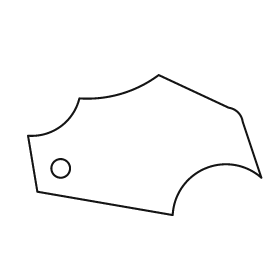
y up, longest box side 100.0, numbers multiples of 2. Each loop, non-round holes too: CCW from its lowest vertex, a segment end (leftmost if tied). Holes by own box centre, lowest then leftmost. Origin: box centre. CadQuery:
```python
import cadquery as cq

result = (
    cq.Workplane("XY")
    .moveTo(12.0, -30.0)
    .threePointArc((26.0, -10.0), (50.0, -14.0))
    .lineTo(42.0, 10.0)
    .threePointArc((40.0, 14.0), (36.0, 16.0))
    .lineTo(6.0, 30.0)
    .threePointArc((-10.0, 22.0), (-28.0, 20.0))
    .threePointArc((-36.0, 8.0), (-50.0, 4.0))
    .lineTo(-46.0, -20.0)
    .close()
    .moveTo(-36.0, -10.0)
    .circle(4.0)
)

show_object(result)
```